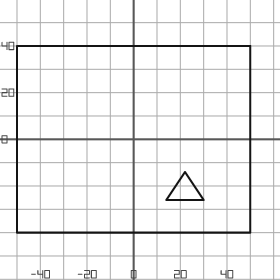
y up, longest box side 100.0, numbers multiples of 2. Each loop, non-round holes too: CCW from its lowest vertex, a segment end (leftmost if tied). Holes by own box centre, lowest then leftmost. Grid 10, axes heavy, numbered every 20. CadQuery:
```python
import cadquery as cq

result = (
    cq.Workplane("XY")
    .moveTo(-50.0, -40.0)
    .lineTo(50.0, -40.0)
    .lineTo(50.0, 40.0)
    .lineTo(-50.0, 40.0)
    .close()
    .moveTo(14.0, -26.0)
    .lineTo(30.0, -26.0)
    .lineTo(22.0, -14.0)
    .close()
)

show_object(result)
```